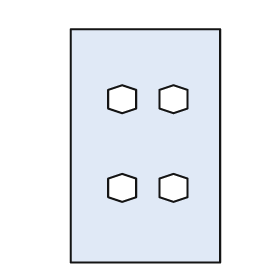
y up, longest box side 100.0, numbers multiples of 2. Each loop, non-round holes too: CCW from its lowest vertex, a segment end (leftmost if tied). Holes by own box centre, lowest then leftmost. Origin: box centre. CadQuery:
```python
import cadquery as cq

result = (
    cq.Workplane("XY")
    .moveTo(-32.0, -50.0)
    .lineTo(32.0, -50.0)
    .lineTo(32.0, 50.0)
    .lineTo(-32.0, 50.0)
    .close()
    .moveTo(-10.0, -24.0)
    .lineTo(-4.0, -22.0)
    .lineTo(-4.0, -14.0)
    .lineTo(-10.0, -12.0)
    .lineTo(-16.0, -14.0)
    .lineTo(-16.0, -22.0)
    .close()
    .moveTo(12.0, -24.0)
    .lineTo(18.0, -22.0)
    .lineTo(18.0, -14.0)
    .lineTo(12.0, -12.0)
    .lineTo(6.0, -14.0)
    .lineTo(6.0, -22.0)
    .close()
    .moveTo(-10.0, 14.0)
    .lineTo(-4.0, 16.0)
    .lineTo(-4.0, 24.0)
    .lineTo(-10.0, 26.0)
    .lineTo(-16.0, 24.0)
    .lineTo(-16.0, 16.0)
    .close()
    .moveTo(12.0, 14.0)
    .lineTo(18.0, 16.0)
    .lineTo(18.0, 24.0)
    .lineTo(12.0, 26.0)
    .lineTo(6.0, 24.0)
    .lineTo(6.0, 16.0)
    .close()
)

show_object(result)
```